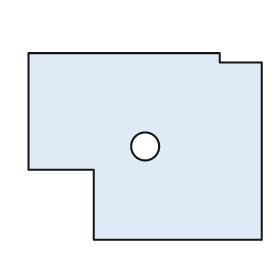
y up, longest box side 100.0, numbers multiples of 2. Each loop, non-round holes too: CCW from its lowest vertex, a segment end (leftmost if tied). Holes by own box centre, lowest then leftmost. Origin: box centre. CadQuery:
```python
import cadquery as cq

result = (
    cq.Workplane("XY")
    .moveTo(-22.0, -40.0)
    .lineTo(50.0, -40.0)
    .lineTo(50.0, 36.0)
    .lineTo(32.0, 36.0)
    .lineTo(32.0, 40.0)
    .lineTo(-50.0, 40.0)
    .lineTo(-50.0, -10.0)
    .lineTo(-22.0, -10.0)
    .close()
    .moveTo(0.0, 0.0)
    .circle(6.0)
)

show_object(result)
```